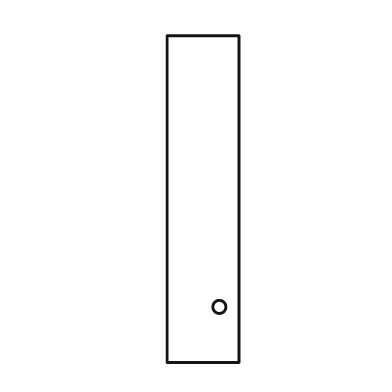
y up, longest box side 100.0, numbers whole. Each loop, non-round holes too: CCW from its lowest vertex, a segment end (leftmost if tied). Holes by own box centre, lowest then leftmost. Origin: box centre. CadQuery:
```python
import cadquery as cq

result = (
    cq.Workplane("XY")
    .moveTo(-11.0, -50.0)
    .lineTo(11.0, -50.0)
    .lineTo(11.0, 50.0)
    .lineTo(-11.0, 50.0)
    .close()
    .moveTo(5.0, -33.0)
    .circle(2.0)
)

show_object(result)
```